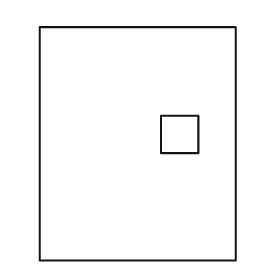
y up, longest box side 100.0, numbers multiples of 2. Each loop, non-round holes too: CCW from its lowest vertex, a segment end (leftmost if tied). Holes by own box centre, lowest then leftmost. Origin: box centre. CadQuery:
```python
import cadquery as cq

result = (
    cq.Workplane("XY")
    .moveTo(-42.0, -50.0)
    .lineTo(42.0, -50.0)
    .lineTo(42.0, 50.0)
    .lineTo(-42.0, 50.0)
    .close()
    .moveTo(10.0, -4.0)
    .lineTo(26.0, -4.0)
    .lineTo(26.0, 12.0)
    .lineTo(10.0, 12.0)
    .close()
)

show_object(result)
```